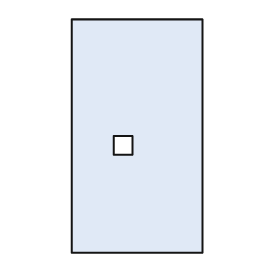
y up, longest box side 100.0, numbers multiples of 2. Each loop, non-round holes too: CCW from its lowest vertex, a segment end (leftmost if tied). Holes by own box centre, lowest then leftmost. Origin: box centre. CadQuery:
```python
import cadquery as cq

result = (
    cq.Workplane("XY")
    .moveTo(-28.0, -50.0)
    .lineTo(28.0, -50.0)
    .lineTo(28.0, 50.0)
    .lineTo(-28.0, 50.0)
    .close()
    .moveTo(-10.0, -8.0)
    .lineTo(-2.0, -8.0)
    .lineTo(-2.0, 0.0)
    .lineTo(-10.0, 0.0)
    .close()
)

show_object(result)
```